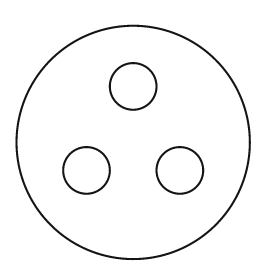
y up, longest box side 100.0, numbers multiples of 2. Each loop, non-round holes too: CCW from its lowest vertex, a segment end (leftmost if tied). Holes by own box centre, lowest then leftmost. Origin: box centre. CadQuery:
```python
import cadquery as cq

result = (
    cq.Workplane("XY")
    .moveTo(0.0, 0.0)
    .circle(50.0)
    .moveTo(-20.0, -12.0)
    .circle(10.0)
    .moveTo(20.0, -12.0)
    .circle(10.0)
    .moveTo(0.0, 24.0)
    .circle(10.0)
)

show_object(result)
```